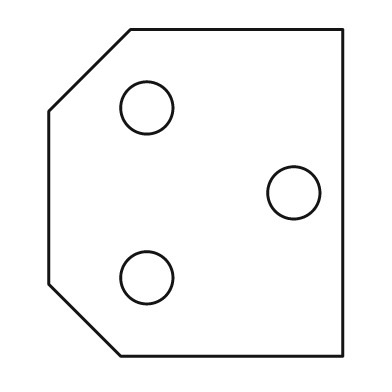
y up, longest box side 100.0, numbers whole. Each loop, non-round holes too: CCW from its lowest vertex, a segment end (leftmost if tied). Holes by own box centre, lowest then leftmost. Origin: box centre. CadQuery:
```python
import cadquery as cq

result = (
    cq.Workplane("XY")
    .moveTo(-23.0, -50.0)
    .lineTo(45.0, -50.0)
    .lineTo(45.0, 50.0)
    .lineTo(-20.0, 50.0)
    .lineTo(-45.0, 25.0)
    .lineTo(-45.0, -28.0)
    .close()
    .moveTo(-15.0, -26.0)
    .circle(8.0)
    .moveTo(30.0, 0.0)
    .circle(8.0)
    .moveTo(-15.0, 26.0)
    .circle(8.0)
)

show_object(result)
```